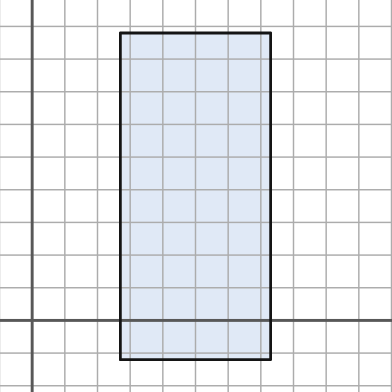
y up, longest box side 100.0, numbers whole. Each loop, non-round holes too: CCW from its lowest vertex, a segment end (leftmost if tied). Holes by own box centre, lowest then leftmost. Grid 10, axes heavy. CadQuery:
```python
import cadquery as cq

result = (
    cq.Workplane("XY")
    .moveTo(27.0, -12.0)
    .lineTo(73.0, -12.0)
    .lineTo(73.0, 88.0)
    .lineTo(27.0, 88.0)
    .close()
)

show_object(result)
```